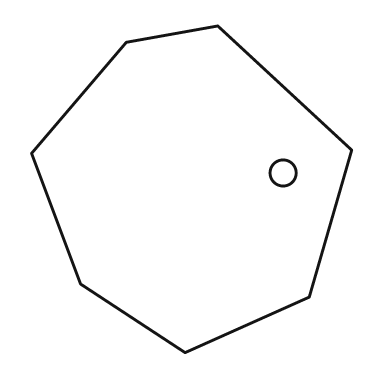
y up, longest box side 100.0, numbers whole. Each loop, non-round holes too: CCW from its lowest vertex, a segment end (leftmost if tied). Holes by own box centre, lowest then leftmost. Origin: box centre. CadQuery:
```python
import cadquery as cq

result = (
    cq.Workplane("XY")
    .moveTo(-2.0, -50.0)
    .lineTo(36.0, -33.0)
    .lineTo(49.0, 12.0)
    .lineTo(8.0, 50.0)
    .lineTo(-20.0, 45.0)
    .lineTo(-49.0, 11.0)
    .lineTo(-34.0, -29.0)
    .close()
    .moveTo(28.0, 5.0)
    .circle(4.0)
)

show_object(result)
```